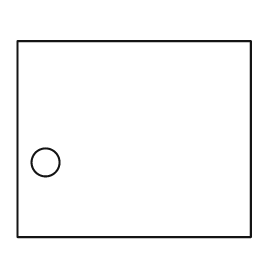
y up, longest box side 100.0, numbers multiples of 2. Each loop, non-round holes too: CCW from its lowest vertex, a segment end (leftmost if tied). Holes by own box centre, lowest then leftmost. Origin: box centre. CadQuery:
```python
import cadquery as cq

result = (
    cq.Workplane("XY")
    .moveTo(-50.0, -42.0)
    .lineTo(50.0, -42.0)
    .lineTo(50.0, 42.0)
    .lineTo(-50.0, 42.0)
    .close()
    .moveTo(-38.0, -10.0)
    .circle(6.0)
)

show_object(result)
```